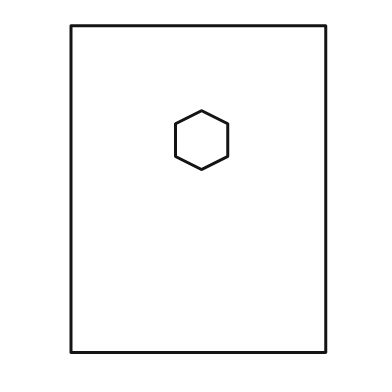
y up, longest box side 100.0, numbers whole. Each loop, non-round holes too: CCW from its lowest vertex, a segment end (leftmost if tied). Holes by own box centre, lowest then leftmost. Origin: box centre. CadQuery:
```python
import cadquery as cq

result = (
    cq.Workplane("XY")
    .moveTo(-39.0, -50.0)
    .lineTo(39.0, -50.0)
    .lineTo(39.0, 50.0)
    .lineTo(-39.0, 50.0)
    .close()
    .moveTo(1.0, 6.0)
    .lineTo(9.0, 10.0)
    .lineTo(9.0, 20.0)
    .lineTo(1.0, 24.0)
    .lineTo(-7.0, 20.0)
    .lineTo(-7.0, 10.0)
    .close()
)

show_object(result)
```